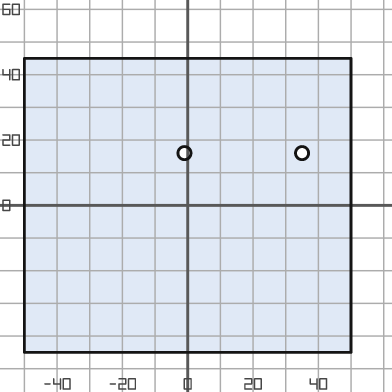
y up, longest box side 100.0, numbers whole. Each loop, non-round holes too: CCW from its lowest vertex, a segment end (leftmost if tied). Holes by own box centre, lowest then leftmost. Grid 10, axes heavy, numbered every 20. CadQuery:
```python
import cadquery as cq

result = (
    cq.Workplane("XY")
    .moveTo(-50.0, -45.0)
    .lineTo(50.0, -45.0)
    .lineTo(50.0, 45.0)
    .lineTo(-50.0, 45.0)
    .close()
    .moveTo(-1.0, 16.0)
    .circle(2.0)
    .moveTo(35.0, 16.0)
    .circle(2.0)
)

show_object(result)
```